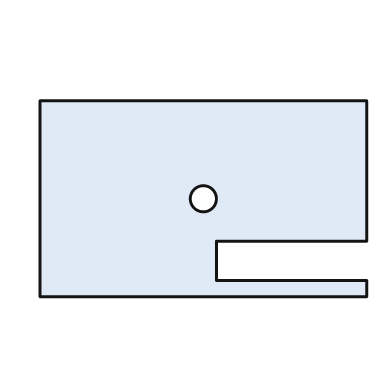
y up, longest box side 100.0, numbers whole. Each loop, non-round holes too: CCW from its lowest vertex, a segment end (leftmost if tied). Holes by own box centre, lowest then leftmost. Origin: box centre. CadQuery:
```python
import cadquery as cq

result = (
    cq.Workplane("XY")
    .moveTo(-50.0, -30.0)
    .lineTo(50.0, -30.0)
    .lineTo(50.0, -25.0)
    .lineTo(4.0, -25.0)
    .lineTo(4.0, -13.0)
    .lineTo(50.0, -13.0)
    .lineTo(50.0, 30.0)
    .lineTo(-50.0, 30.0)
    .close()
    .moveTo(0.0, 0.0)
    .circle(4.0)
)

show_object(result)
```